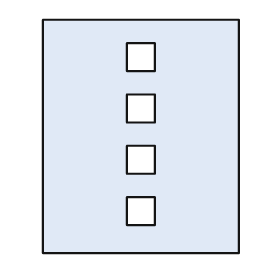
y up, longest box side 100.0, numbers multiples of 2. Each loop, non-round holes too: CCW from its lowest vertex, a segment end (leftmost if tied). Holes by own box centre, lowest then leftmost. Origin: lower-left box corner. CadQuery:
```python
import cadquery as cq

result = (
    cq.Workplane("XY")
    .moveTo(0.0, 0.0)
    .lineTo(84.0, 0.0)
    .lineTo(84.0, 100.0)
    .lineTo(0.0, 100.0)
    .close()
    .moveTo(36.0, 12.0)
    .lineTo(48.0, 12.0)
    .lineTo(48.0, 24.0)
    .lineTo(36.0, 24.0)
    .close()
    .moveTo(36.0, 34.0)
    .lineTo(48.0, 34.0)
    .lineTo(48.0, 46.0)
    .lineTo(36.0, 46.0)
    .close()
    .moveTo(36.0, 56.0)
    .lineTo(48.0, 56.0)
    .lineTo(48.0, 68.0)
    .lineTo(36.0, 68.0)
    .close()
    .moveTo(36.0, 78.0)
    .lineTo(48.0, 78.0)
    .lineTo(48.0, 90.0)
    .lineTo(36.0, 90.0)
    .close()
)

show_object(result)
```